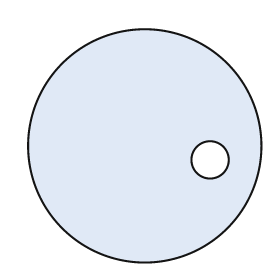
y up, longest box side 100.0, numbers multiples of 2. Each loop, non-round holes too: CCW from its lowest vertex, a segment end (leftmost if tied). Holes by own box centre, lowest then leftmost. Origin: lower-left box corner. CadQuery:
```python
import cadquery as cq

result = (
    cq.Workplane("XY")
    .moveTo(50.0, 50.0)
    .circle(50.0)
    .moveTo(78.0, 44.0)
    .circle(8.0)
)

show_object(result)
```